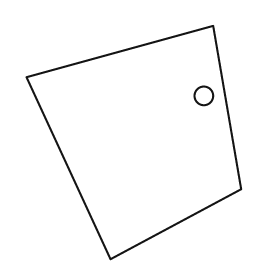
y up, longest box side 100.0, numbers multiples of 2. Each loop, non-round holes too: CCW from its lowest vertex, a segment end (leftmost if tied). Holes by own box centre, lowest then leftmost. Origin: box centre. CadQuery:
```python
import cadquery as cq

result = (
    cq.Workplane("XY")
    .moveTo(-10.0, -50.0)
    .lineTo(46.0, -20.0)
    .lineTo(34.0, 50.0)
    .lineTo(-46.0, 28.0)
    .close()
    .moveTo(30.0, 20.0)
    .circle(4.0)
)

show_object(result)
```